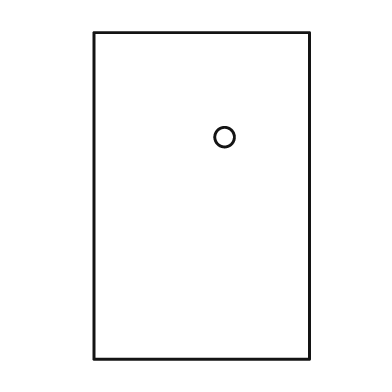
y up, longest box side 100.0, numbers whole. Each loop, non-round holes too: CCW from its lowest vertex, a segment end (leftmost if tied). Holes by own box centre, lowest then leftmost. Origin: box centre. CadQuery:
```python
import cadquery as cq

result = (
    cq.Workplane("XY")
    .moveTo(-33.0, -50.0)
    .lineTo(33.0, -50.0)
    .lineTo(33.0, 50.0)
    .lineTo(-33.0, 50.0)
    .close()
    .moveTo(7.0, 18.0)
    .circle(3.0)
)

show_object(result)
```